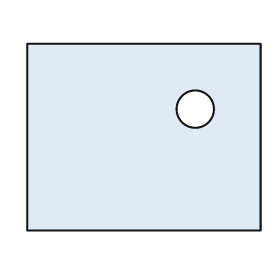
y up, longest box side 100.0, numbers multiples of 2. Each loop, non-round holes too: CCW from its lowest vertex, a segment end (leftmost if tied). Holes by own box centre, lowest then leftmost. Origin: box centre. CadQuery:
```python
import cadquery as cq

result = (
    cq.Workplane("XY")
    .moveTo(-50.0, -40.0)
    .lineTo(50.0, -40.0)
    .lineTo(50.0, 40.0)
    .lineTo(-50.0, 40.0)
    .close()
    .moveTo(22.0, 12.0)
    .circle(8.0)
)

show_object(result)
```